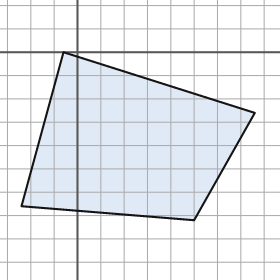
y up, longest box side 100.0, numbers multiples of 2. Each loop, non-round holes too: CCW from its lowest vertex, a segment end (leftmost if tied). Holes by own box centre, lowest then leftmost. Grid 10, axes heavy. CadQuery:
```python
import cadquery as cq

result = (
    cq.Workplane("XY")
    .moveTo(50.0, -72.0)
    .lineTo(76.0, -26.0)
    .lineTo(-6.0, 0.0)
    .lineTo(-24.0, -66.0)
    .close()
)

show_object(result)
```